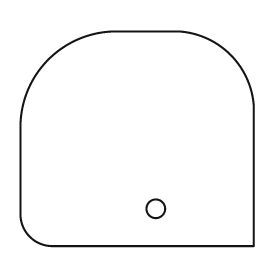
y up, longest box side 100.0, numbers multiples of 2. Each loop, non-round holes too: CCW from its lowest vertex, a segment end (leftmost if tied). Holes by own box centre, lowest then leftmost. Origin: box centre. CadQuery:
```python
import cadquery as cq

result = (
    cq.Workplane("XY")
    .moveTo(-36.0, -46.0)
    .lineTo(50.0, -46.0)
    .lineTo(50.0, 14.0)
    .threePointArc((40.0, 36.0), (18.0, 46.0))
    .lineTo(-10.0, 46.0)
    .threePointArc((-38.0, 34.0), (-50.0, 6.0))
    .lineTo(-50.0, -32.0)
    .threePointArc((-46.0, -42.0), (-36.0, -46.0))
    .close()
    .moveTo(8.0, -30.0)
    .circle(4.0)
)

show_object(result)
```